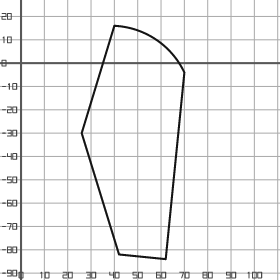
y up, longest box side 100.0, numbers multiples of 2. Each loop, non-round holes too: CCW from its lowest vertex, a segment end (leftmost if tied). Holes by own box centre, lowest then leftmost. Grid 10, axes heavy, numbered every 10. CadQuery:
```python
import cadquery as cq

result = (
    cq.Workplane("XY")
    .moveTo(62.0, -84.0)
    .lineTo(70.0, -4.0)
    .threePointArc((58.0, 10.0), (40.0, 16.0))
    .lineTo(26.0, -30.0)
    .lineTo(42.0, -82.0)
    .close()
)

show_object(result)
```